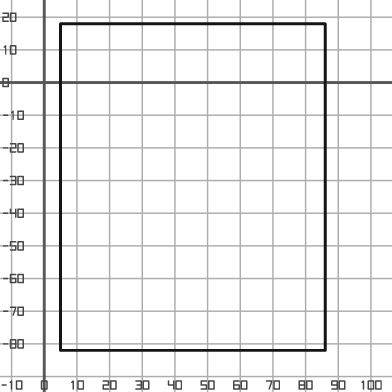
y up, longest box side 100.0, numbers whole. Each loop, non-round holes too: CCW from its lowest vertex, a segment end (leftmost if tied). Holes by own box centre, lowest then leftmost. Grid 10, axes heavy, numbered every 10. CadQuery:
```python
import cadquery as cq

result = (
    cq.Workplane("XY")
    .moveTo(5.0, -82.0)
    .lineTo(86.0, -82.0)
    .lineTo(86.0, 18.0)
    .lineTo(5.0, 18.0)
    .close()
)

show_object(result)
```